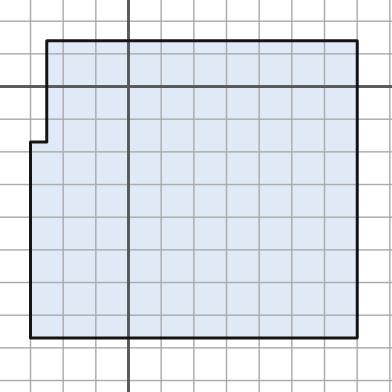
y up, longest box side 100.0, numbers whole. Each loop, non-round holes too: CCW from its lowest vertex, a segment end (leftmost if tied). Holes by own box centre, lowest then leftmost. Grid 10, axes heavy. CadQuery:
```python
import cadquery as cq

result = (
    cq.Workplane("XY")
    .moveTo(-30.0, -77.0)
    .lineTo(70.0, -77.0)
    .lineTo(70.0, 14.0)
    .lineTo(-25.0, 14.0)
    .lineTo(-25.0, -17.0)
    .lineTo(-30.0, -17.0)
    .close()
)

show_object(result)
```